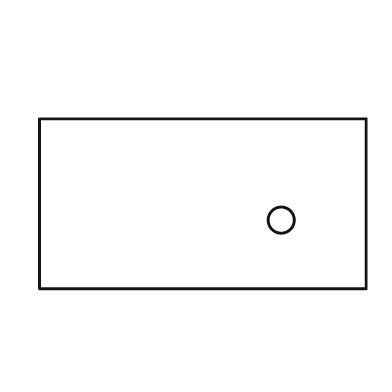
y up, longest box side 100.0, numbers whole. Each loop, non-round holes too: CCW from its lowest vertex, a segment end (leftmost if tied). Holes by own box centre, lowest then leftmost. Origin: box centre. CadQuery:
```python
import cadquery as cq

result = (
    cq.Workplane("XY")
    .moveTo(-50.0, -26.0)
    .lineTo(50.0, -26.0)
    .lineTo(50.0, 26.0)
    .lineTo(-50.0, 26.0)
    .close()
    .moveTo(24.0, -5.0)
    .circle(4.0)
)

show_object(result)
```